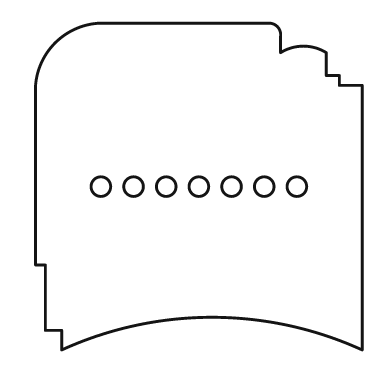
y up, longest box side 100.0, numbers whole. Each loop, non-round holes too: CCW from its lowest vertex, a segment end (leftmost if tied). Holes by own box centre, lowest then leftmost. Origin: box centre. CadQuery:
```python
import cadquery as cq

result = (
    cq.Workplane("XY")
    .moveTo(-42.0, -50.0)
    .threePointArc((4.0, -40.0), (50.0, -50.0))
    .lineTo(50.0, 31.0)
    .lineTo(43.0, 31.0)
    .lineTo(43.0, 34.0)
    .lineTo(39.0, 34.0)
    .lineTo(39.0, 41.0)
    .threePointArc((32.0, 43.0), (25.0, 41.0))
    .lineTo(25.0, 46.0)
    .threePointArc((24.0, 49.0), (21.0, 50.0))
    .lineTo(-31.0, 50.0)
    .threePointArc((-44.0, 44.0), (-50.0, 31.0))
    .lineTo(-50.0, -24.0)
    .lineTo(-47.0, -24.0)
    .lineTo(-47.0, -44.0)
    .lineTo(-42.0, -44.0)
    .close()
    .moveTo(-30.0, 0.0)
    .circle(3.0)
    .moveTo(-20.0, 0.0)
    .circle(3.0)
    .moveTo(-10.0, 0.0)
    .circle(3.0)
    .moveTo(0.0, 0.0)
    .circle(3.0)
    .moveTo(10.0, 0.0)
    .circle(3.0)
    .moveTo(20.0, 0.0)
    .circle(3.0)
    .moveTo(30.0, 0.0)
    .circle(3.0)
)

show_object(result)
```